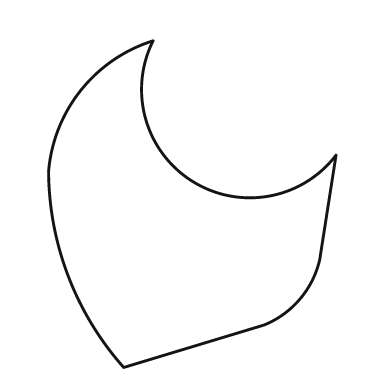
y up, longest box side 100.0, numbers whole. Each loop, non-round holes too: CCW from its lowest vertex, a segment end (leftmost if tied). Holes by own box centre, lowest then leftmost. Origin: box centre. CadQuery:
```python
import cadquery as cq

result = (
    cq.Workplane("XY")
    .moveTo(-21.0, -50.0)
    .lineTo(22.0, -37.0)
    .threePointArc((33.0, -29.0), (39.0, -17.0))
    .lineTo(44.0, 15.0)
    .threePointArc((0.0, 7.0), (-12.0, 50.0))
    .threePointArc((-34.0, 35.0), (-44.0, 10.0))
    .threePointArc((-38.0, -22.0), (-21.0, -50.0))
    .close()
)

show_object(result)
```